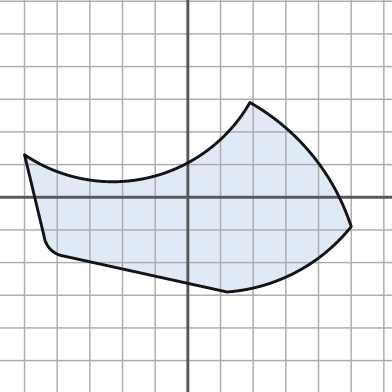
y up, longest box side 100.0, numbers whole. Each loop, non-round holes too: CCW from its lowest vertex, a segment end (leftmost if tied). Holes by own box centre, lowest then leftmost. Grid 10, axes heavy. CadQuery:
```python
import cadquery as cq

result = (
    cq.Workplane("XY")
    .moveTo(12.0, -29.0)
    .threePointArc((33.0, -23.0), (50.0, -9.0))
    .threePointArc((38.0, 13.0), (19.0, 29.0))
    .threePointArc((-12.0, 6.0), (-50.0, 13.0))
    .lineTo(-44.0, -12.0)
    .threePointArc((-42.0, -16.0), (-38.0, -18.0))
    .close()
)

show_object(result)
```